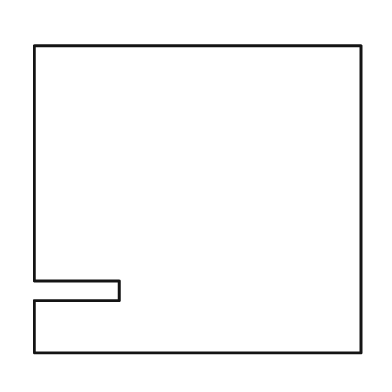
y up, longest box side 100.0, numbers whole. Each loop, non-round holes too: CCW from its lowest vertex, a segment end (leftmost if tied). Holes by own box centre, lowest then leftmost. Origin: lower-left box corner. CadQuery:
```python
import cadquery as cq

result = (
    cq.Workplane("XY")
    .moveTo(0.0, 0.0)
    .lineTo(100.0, 0.0)
    .lineTo(100.0, 94.0)
    .lineTo(0.0, 94.0)
    .lineTo(0.0, 22.0)
    .lineTo(26.0, 22.0)
    .lineTo(26.0, 16.0)
    .lineTo(0.0, 16.0)
    .close()
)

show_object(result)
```